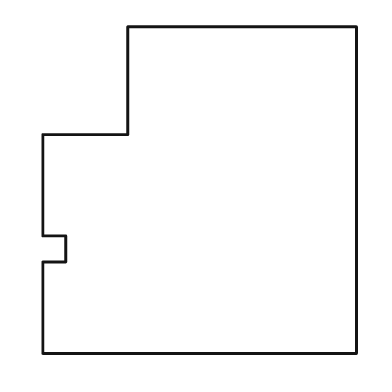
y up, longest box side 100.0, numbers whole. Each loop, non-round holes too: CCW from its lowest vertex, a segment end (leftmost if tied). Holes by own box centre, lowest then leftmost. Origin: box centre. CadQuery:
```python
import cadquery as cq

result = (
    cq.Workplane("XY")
    .moveTo(-48.0, -50.0)
    .lineTo(48.0, -50.0)
    .lineTo(48.0, 50.0)
    .lineTo(-22.0, 50.0)
    .lineTo(-22.0, 17.0)
    .lineTo(-48.0, 17.0)
    .lineTo(-48.0, -14.0)
    .lineTo(-41.0, -14.0)
    .lineTo(-41.0, -22.0)
    .lineTo(-48.0, -22.0)
    .close()
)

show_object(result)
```